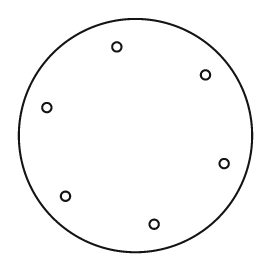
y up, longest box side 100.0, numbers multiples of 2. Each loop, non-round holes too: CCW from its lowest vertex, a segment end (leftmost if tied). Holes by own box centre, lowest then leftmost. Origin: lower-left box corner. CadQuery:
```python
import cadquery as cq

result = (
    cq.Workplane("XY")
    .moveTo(50.0, 50.0)
    .circle(50.0)
    .moveTo(58.0, 12.0)
    .circle(2.0)
    .moveTo(20.0, 24.0)
    .circle(2.0)
    .moveTo(88.0, 38.0)
    .circle(2.0)
    .moveTo(12.0, 62.0)
    .circle(2.0)
    .moveTo(80.0, 76.0)
    .circle(2.0)
    .moveTo(42.0, 88.0)
    .circle(2.0)
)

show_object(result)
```